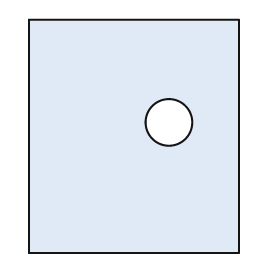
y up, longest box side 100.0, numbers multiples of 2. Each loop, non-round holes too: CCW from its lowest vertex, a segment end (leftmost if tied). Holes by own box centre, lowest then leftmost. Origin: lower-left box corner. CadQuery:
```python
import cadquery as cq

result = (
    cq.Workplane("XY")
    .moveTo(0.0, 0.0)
    .lineTo(90.0, 0.0)
    .lineTo(90.0, 100.0)
    .lineTo(0.0, 100.0)
    .close()
    .moveTo(60.0, 56.0)
    .circle(10.0)
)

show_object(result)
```